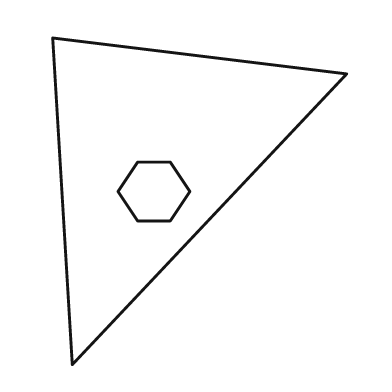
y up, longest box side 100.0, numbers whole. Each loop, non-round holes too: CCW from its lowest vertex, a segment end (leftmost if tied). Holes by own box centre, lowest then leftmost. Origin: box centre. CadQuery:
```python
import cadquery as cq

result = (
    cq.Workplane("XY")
    .moveTo(-39.0, -50.0)
    .lineTo(45.0, 39.0)
    .lineTo(-45.0, 50.0)
    .close()
    .moveTo(-19.0, -6.0)
    .lineTo(-9.0, -6.0)
    .lineTo(-3.0, 3.0)
    .lineTo(-9.0, 12.0)
    .lineTo(-19.0, 12.0)
    .lineTo(-25.0, 3.0)
    .close()
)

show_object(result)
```